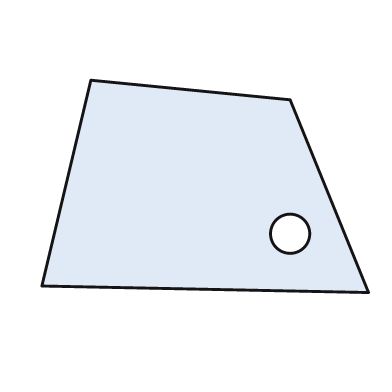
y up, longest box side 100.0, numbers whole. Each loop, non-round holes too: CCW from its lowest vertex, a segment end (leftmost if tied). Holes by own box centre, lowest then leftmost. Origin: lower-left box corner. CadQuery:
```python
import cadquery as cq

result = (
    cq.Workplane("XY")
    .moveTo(100.0, 0.0)
    .lineTo(76.0, 59.0)
    .lineTo(15.0, 65.0)
    .lineTo(0.0, 2.0)
    .close()
    .moveTo(76.0, 18.0)
    .circle(6.0)
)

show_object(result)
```